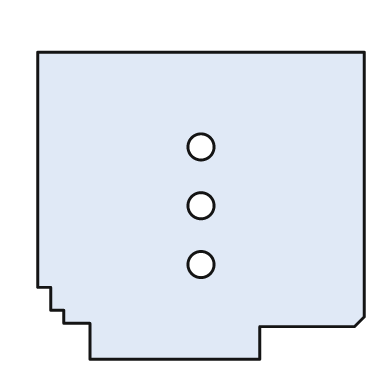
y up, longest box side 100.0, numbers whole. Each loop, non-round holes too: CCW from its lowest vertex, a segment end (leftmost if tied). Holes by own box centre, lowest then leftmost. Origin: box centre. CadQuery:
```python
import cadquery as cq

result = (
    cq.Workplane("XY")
    .moveTo(-34.0, -47.0)
    .lineTo(18.0, -47.0)
    .lineTo(18.0, -37.0)
    .lineTo(47.0, -37.0)
    .lineTo(50.0, -34.0)
    .lineTo(50.0, 47.0)
    .lineTo(-50.0, 47.0)
    .lineTo(-50.0, -25.0)
    .lineTo(-46.0, -25.0)
    .lineTo(-46.0, -32.0)
    .lineTo(-42.0, -32.0)
    .lineTo(-42.0, -36.0)
    .lineTo(-34.0, -36.0)
    .close()
    .moveTo(0.0, -18.0)
    .circle(4.0)
    .moveTo(0.0, 0.0)
    .circle(4.0)
    .moveTo(0.0, 18.0)
    .circle(4.0)
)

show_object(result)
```